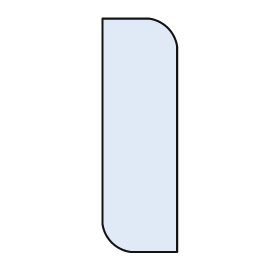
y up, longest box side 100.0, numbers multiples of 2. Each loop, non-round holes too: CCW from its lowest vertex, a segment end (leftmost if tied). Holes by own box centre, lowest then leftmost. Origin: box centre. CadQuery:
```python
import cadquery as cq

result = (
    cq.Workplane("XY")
    .moveTo(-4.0, -50.0)
    .lineTo(16.0, -50.0)
    .lineTo(16.0, 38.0)
    .threePointArc((12.0, 46.0), (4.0, 50.0))
    .lineTo(-16.0, 50.0)
    .lineTo(-16.0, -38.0)
    .threePointArc((-12.0, -46.0), (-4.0, -50.0))
    .close()
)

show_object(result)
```